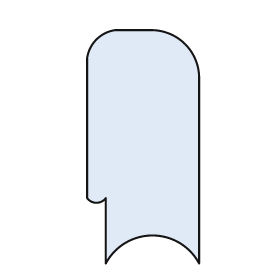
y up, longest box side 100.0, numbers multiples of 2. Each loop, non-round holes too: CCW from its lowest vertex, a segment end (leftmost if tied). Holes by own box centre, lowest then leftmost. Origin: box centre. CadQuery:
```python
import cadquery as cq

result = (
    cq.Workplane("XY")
    .moveTo(-16.0, -50.0)
    .threePointArc((4.0, -38.0), (24.0, -50.0))
    .lineTo(24.0, 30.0)
    .threePointArc((18.0, 44.0), (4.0, 50.0))
    .lineTo(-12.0, 50.0)
    .threePointArc((-20.0, 46.0), (-24.0, 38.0))
    .lineTo(-24.0, -22.0)
    .threePointArc((-20.0, -24.0), (-16.0, -22.0))
    .close()
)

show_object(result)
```